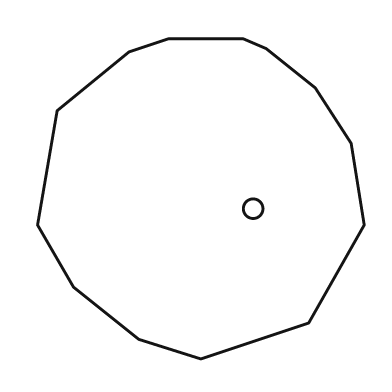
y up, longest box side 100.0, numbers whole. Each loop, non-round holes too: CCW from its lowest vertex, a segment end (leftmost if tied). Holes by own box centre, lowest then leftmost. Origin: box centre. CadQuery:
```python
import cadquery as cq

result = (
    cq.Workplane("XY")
    .moveTo(0.0, -49.0)
    .lineTo(33.0, -38.0)
    .lineTo(50.0, -8.0)
    .lineTo(46.0, 17.0)
    .lineTo(35.0, 34.0)
    .lineTo(20.0, 46.0)
    .lineTo(13.0, 49.0)
    .lineTo(-10.0, 49.0)
    .lineTo(-22.0, 45.0)
    .lineTo(-44.0, 27.0)
    .lineTo(-50.0, -8.0)
    .lineTo(-39.0, -27.0)
    .lineTo(-19.0, -43.0)
    .close()
    .moveTo(16.0, -3.0)
    .circle(3.0)
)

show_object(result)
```